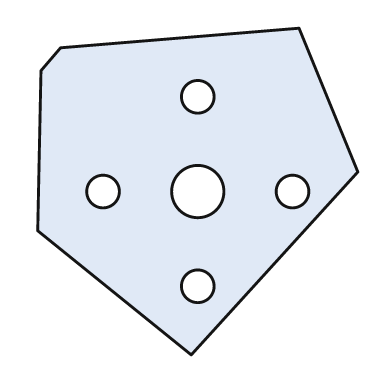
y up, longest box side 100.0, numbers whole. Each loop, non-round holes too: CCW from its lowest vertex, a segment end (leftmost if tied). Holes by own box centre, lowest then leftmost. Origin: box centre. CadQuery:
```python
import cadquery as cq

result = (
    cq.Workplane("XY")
    .moveTo(-2.0, -50.0)
    .lineTo(49.0, 6.0)
    .lineTo(31.0, 50.0)
    .lineTo(-42.0, 44.0)
    .lineTo(-48.0, 37.0)
    .lineTo(-49.0, -12.0)
    .close()
    .moveTo(0.0, -29.0)
    .circle(5.0)
    .moveTo(-29.0, 0.0)
    .circle(5.0)
    .moveTo(0.0, 0.0)
    .circle(8.0)
    .moveTo(29.0, 0.0)
    .circle(5.0)
    .moveTo(0.0, 29.0)
    .circle(5.0)
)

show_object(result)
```